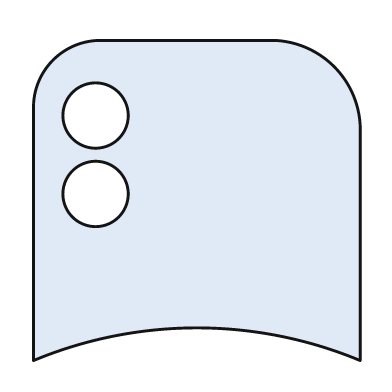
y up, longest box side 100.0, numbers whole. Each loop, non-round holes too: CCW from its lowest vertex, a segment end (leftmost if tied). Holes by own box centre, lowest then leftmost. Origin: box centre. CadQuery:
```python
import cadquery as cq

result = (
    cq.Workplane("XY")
    .moveTo(-50.0, -49.0)
    .threePointArc((0.0, -39.0), (50.0, -49.0))
    .lineTo(50.0, 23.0)
    .threePointArc((42.0, 41.0), (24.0, 49.0))
    .lineTo(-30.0, 49.0)
    .threePointArc((-44.0, 43.0), (-50.0, 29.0))
    .close()
    .moveTo(-31.0, 2.0)
    .circle(10.0)
    .moveTo(-31.0, 26.0)
    .circle(10.0)
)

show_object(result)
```